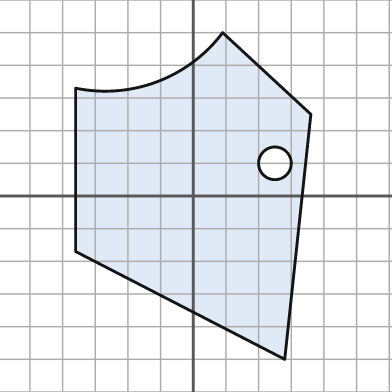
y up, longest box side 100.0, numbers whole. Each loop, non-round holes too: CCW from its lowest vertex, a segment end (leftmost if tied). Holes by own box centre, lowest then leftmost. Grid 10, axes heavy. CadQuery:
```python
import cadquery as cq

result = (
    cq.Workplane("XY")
    .moveTo(28.0, -50.0)
    .lineTo(36.0, 25.0)
    .lineTo(9.0, 50.0)
    .threePointArc((-11.0, 35.0), (-36.0, 33.0))
    .lineTo(-36.0, -17.0)
    .close()
    .moveTo(25.0, 10.0)
    .circle(5.0)
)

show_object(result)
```